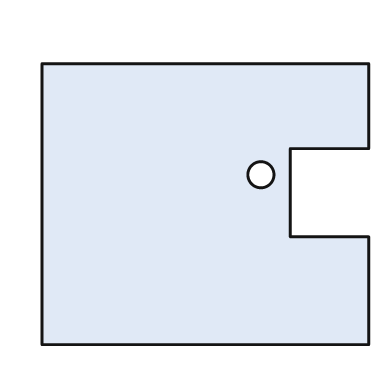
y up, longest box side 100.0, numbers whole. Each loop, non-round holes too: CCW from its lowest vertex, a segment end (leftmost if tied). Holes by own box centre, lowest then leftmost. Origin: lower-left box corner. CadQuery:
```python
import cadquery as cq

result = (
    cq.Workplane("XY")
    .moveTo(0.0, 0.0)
    .lineTo(100.0, 0.0)
    .lineTo(100.0, 33.0)
    .lineTo(76.0, 33.0)
    .lineTo(76.0, 60.0)
    .lineTo(100.0, 60.0)
    .lineTo(100.0, 86.0)
    .lineTo(0.0, 86.0)
    .close()
    .moveTo(67.0, 52.0)
    .circle(4.0)
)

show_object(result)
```